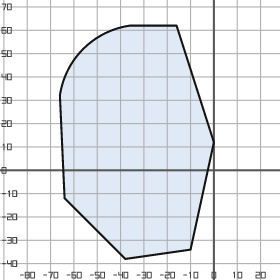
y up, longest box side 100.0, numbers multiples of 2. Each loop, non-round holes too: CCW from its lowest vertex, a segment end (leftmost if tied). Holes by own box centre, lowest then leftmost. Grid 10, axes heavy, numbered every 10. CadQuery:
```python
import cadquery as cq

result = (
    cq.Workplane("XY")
    .moveTo(-38.0, -38.0)
    .lineTo(-10.0, -34.0)
    .lineTo(0.0, 12.0)
    .lineTo(-16.0, 62.0)
    .lineTo(-36.0, 62.0)
    .threePointArc((-56.0, 52.0), (-66.0, 32.0))
    .lineTo(-64.0, -12.0)
    .close()
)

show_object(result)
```